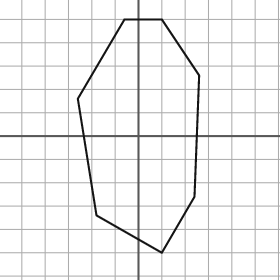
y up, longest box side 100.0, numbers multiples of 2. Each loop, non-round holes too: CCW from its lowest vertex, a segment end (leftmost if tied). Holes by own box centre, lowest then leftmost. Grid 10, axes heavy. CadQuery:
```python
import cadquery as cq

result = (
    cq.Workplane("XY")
    .moveTo(10.0, -50.0)
    .lineTo(24.0, -26.0)
    .lineTo(26.0, 26.0)
    .lineTo(10.0, 50.0)
    .lineTo(-6.0, 50.0)
    .lineTo(-26.0, 16.0)
    .lineTo(-18.0, -34.0)
    .close()
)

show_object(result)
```